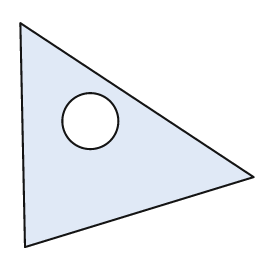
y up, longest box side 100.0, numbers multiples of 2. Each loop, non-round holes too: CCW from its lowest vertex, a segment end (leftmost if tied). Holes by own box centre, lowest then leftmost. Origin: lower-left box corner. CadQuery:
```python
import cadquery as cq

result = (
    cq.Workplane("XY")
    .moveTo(2.0, 0.0)
    .lineTo(100.0, 30.0)
    .lineTo(0.0, 96.0)
    .close()
    .moveTo(30.0, 54.0)
    .circle(12.0)
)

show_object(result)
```